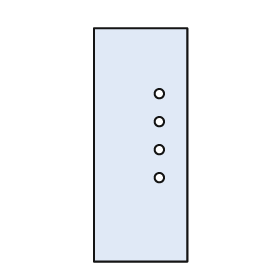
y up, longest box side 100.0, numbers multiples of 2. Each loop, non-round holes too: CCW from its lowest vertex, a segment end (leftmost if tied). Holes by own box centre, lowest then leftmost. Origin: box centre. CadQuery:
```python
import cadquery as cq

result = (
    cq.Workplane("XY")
    .moveTo(-20.0, -50.0)
    .lineTo(20.0, -50.0)
    .lineTo(20.0, 50.0)
    .lineTo(-20.0, 50.0)
    .close()
    .moveTo(8.0, -14.0)
    .circle(2.0)
    .moveTo(8.0, -2.0)
    .circle(2.0)
    .moveTo(8.0, 10.0)
    .circle(2.0)
    .moveTo(8.0, 22.0)
    .circle(2.0)
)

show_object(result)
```